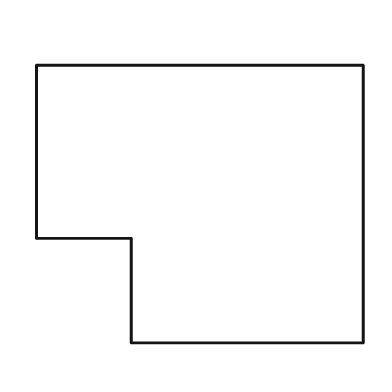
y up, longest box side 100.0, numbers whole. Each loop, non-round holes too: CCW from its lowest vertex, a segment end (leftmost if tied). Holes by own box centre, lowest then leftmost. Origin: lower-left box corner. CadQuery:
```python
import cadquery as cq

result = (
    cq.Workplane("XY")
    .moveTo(29.0, 0.0)
    .lineTo(100.0, 0.0)
    .lineTo(100.0, 85.0)
    .lineTo(0.0, 85.0)
    .lineTo(0.0, 32.0)
    .lineTo(29.0, 32.0)
    .close()
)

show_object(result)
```